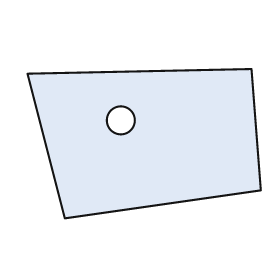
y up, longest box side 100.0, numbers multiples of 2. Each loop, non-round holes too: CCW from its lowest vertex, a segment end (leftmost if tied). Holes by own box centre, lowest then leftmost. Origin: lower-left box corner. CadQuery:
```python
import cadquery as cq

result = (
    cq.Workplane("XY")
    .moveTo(16.0, 0.0)
    .lineTo(100.0, 12.0)
    .lineTo(96.0, 64.0)
    .lineTo(0.0, 62.0)
    .close()
    .moveTo(40.0, 42.0)
    .circle(6.0)
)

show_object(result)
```